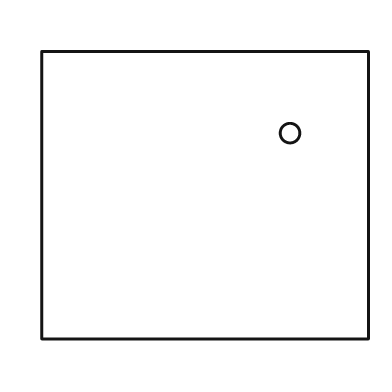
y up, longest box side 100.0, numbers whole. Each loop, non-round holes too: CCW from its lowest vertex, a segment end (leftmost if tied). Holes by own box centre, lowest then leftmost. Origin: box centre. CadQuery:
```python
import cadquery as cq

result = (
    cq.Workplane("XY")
    .moveTo(-50.0, -44.0)
    .lineTo(50.0, -44.0)
    .lineTo(50.0, 44.0)
    .lineTo(-50.0, 44.0)
    .close()
    .moveTo(26.0, 19.0)
    .circle(3.0)
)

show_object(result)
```